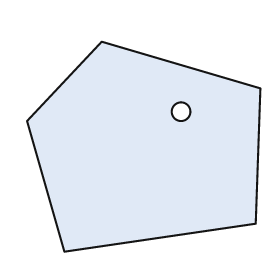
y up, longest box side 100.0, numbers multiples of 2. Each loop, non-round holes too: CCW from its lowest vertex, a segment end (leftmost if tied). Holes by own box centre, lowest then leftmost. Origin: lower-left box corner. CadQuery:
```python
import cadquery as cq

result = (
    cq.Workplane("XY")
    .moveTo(16.0, 0.0)
    .lineTo(98.0, 12.0)
    .lineTo(100.0, 70.0)
    .lineTo(32.0, 90.0)
    .lineTo(0.0, 56.0)
    .close()
    .moveTo(66.0, 60.0)
    .circle(4.0)
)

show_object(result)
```